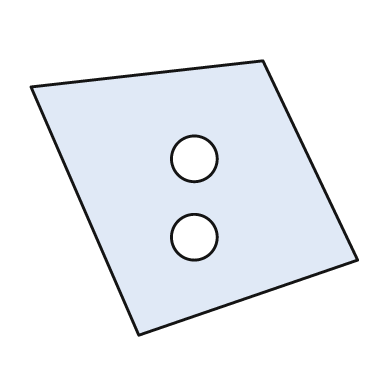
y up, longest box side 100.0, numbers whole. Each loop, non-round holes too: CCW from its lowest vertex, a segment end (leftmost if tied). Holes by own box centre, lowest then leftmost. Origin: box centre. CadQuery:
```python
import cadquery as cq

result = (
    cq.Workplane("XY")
    .moveTo(-17.0, -42.0)
    .lineTo(50.0, -19.0)
    .lineTo(21.0, 42.0)
    .lineTo(-50.0, 34.0)
    .close()
    .moveTo(0.0, -12.0)
    .circle(7.0)
    .moveTo(0.0, 12.0)
    .circle(7.0)
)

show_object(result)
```